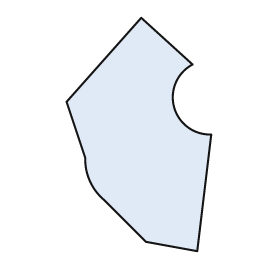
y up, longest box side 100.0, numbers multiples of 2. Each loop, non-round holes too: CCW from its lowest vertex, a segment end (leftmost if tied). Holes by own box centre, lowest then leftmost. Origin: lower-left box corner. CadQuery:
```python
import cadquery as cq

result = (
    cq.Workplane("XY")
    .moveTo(56.0, 0.0)
    .lineTo(62.0, 50.0)
    .threePointArc((46.0, 62.0), (54.0, 80.0))
    .lineTo(32.0, 100.0)
    .lineTo(0.0, 64.0)
    .lineTo(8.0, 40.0)
    .threePointArc((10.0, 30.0), (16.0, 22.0))
    .lineTo(34.0, 4.0)
    .close()
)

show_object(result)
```